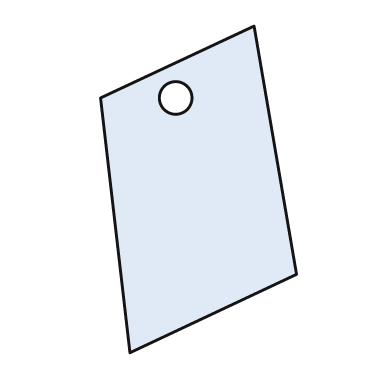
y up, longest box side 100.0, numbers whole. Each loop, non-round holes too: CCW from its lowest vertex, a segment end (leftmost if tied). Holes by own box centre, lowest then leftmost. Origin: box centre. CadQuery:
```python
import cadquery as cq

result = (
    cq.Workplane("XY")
    .moveTo(-21.0, -50.0)
    .lineTo(30.0, -26.0)
    .lineTo(17.0, 50.0)
    .lineTo(-30.0, 28.0)
    .close()
    .moveTo(-7.0, 28.0)
    .circle(5.0)
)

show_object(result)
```